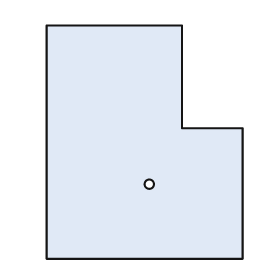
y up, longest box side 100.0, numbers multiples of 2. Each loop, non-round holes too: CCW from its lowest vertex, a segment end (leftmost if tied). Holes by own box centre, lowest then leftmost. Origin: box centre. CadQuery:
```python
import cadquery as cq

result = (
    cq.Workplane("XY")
    .moveTo(-42.0, -50.0)
    .lineTo(42.0, -50.0)
    .lineTo(42.0, 6.0)
    .lineTo(16.0, 6.0)
    .lineTo(16.0, 50.0)
    .lineTo(-42.0, 50.0)
    .close()
    .moveTo(2.0, -18.0)
    .circle(2.0)
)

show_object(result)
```